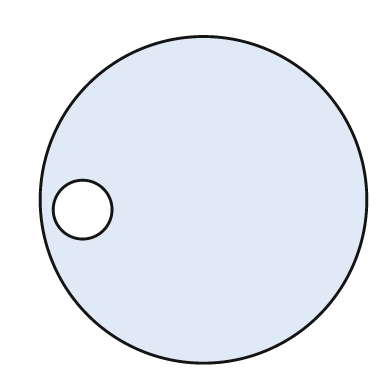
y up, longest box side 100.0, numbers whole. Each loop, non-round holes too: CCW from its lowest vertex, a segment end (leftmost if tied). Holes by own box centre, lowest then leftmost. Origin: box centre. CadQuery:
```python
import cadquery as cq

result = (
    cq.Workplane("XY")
    .moveTo(0.0, 0.0)
    .circle(50.0)
    .moveTo(-37.0, -3.0)
    .circle(9.0)
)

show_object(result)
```